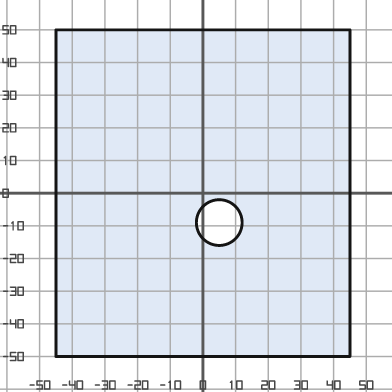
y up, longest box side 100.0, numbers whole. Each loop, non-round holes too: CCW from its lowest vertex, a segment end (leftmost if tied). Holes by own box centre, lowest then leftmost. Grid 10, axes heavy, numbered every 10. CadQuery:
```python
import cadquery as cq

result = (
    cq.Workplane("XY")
    .moveTo(-45.0, -50.0)
    .lineTo(45.0, -50.0)
    .lineTo(45.0, 50.0)
    .lineTo(-45.0, 50.0)
    .close()
    .moveTo(5.0, -9.0)
    .circle(7.0)
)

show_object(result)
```